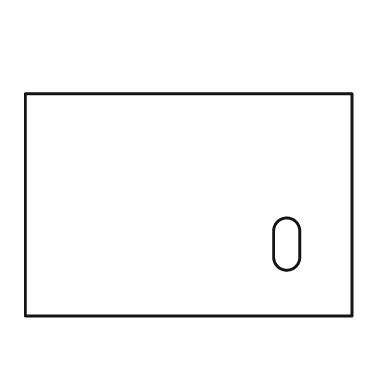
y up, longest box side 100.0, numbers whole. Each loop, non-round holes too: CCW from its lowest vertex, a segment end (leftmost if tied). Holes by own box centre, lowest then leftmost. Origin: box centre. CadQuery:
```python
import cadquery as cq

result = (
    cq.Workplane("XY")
    .moveTo(-50.0, -34.0)
    .lineTo(50.0, -34.0)
    .lineTo(50.0, 34.0)
    .lineTo(-50.0, 34.0)
    .close()
    .moveTo(26.0, -16.0)
    .threePointArc((30.0, -20.0), (34.0, -16.0))
    .lineTo(34.0, -8.0)
    .threePointArc((30.0, -4.0), (26.0, -8.0))
    .close()
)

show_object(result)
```